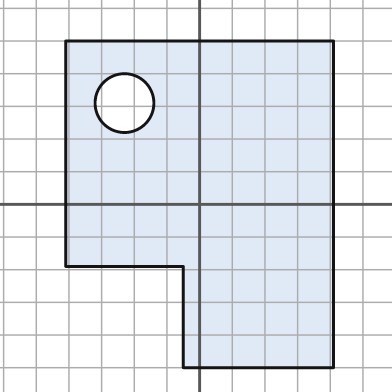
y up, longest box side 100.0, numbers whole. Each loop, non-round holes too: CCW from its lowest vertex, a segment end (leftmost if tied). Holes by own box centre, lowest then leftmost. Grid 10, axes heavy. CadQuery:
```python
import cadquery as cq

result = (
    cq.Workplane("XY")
    .moveTo(-5.0, -50.0)
    .lineTo(41.0, -50.0)
    .lineTo(41.0, 50.0)
    .lineTo(-41.0, 50.0)
    .lineTo(-41.0, -19.0)
    .lineTo(-5.0, -19.0)
    .close()
    .moveTo(-23.0, 31.0)
    .circle(9.0)
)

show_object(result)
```